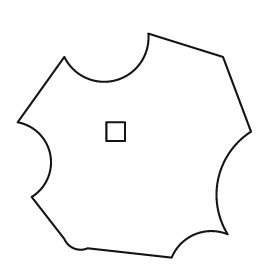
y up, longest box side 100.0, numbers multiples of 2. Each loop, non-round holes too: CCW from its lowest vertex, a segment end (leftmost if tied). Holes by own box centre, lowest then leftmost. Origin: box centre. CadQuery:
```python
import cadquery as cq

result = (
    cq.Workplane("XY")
    .moveTo(16.0, -48.0)
    .threePointArc((26.0, -38.0), (40.0, -38.0))
    .threePointArc((36.0, -14.0), (50.0, 6.0))
    .lineTo(38.0, 38.0)
    .lineTo(6.0, 48.0)
    .threePointArc((-8.0, 28.0), (-30.0, 38.0))
    .lineTo(-50.0, 10.0)
    .threePointArc((-36.0, -4.0), (-44.0, -22.0))
    .lineTo(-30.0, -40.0)
    .threePointArc((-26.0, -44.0), (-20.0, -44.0))
    .close()
    .moveTo(-12.0, 2.0)
    .lineTo(-4.0, 2.0)
    .lineTo(-4.0, 10.0)
    .lineTo(-12.0, 10.0)
    .close()
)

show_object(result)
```